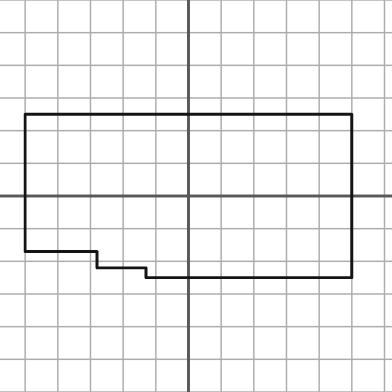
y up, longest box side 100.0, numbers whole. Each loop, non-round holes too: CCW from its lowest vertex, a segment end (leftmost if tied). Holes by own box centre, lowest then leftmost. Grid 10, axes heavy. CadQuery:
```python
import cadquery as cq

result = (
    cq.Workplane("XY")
    .moveTo(-13.0, -25.0)
    .lineTo(50.0, -25.0)
    .lineTo(50.0, 25.0)
    .lineTo(-50.0, 25.0)
    .lineTo(-50.0, -17.0)
    .lineTo(-28.0, -17.0)
    .lineTo(-28.0, -22.0)
    .lineTo(-13.0, -22.0)
    .close()
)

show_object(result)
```